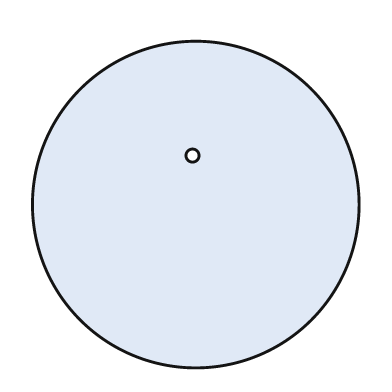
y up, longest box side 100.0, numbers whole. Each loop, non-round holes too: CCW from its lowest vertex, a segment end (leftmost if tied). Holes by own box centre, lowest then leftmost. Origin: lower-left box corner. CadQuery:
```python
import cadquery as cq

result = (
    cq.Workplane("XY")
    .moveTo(50.0, 50.0)
    .circle(50.0)
    .moveTo(49.0, 65.0)
    .circle(2.0)
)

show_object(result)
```